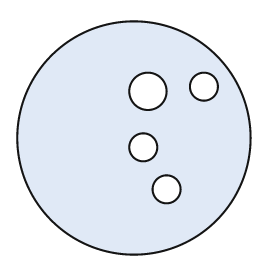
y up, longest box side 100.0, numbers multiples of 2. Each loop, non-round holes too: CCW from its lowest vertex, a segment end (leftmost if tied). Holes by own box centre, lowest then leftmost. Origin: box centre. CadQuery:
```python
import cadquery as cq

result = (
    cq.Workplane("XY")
    .moveTo(0.0, 0.0)
    .circle(50.0)
    .moveTo(14.0, -22.0)
    .circle(6.0)
    .moveTo(4.0, -4.0)
    .circle(6.0)
    .moveTo(6.0, 20.0)
    .circle(8.0)
    .moveTo(30.0, 22.0)
    .circle(6.0)
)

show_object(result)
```